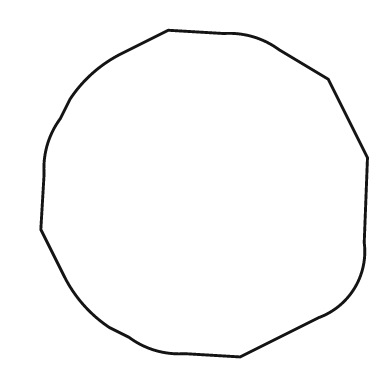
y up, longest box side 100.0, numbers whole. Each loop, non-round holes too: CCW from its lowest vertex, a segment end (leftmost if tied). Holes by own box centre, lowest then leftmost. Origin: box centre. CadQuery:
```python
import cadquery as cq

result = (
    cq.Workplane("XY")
    .moveTo(11.0, -50.0)
    .lineTo(35.0, -38.0)
    .threePointArc((46.0, -29.0), (49.0, -15.0))
    .lineTo(50.0, 11.0)
    .lineTo(38.0, 35.0)
    .lineTo(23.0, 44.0)
    .threePointArc((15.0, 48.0), (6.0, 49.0))
    .lineTo(-11.0, 50.0)
    .lineTo(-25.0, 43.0)
    .threePointArc((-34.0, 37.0), (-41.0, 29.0))
    .lineTo(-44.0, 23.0)
    .threePointArc((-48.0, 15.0), (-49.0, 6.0))
    .lineTo(-50.0, -11.0)
    .lineTo(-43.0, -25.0)
    .threePointArc((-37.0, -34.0), (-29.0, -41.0))
    .lineTo(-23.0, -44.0)
    .threePointArc((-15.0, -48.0), (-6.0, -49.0))
    .close()
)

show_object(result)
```